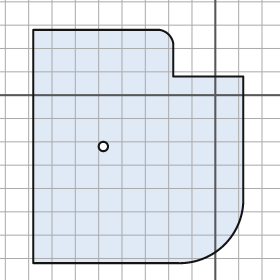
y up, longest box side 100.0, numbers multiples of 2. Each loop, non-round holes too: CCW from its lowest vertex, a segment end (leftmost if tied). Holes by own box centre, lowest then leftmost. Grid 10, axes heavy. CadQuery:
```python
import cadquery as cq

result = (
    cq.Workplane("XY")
    .moveTo(-78.0, -72.0)
    .lineTo(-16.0, -72.0)
    .threePointArc((4.0, -64.0), (12.0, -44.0))
    .lineTo(12.0, 8.0)
    .lineTo(-18.0, 8.0)
    .lineTo(-18.0, 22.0)
    .threePointArc((-20.0, 26.0), (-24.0, 28.0))
    .lineTo(-78.0, 28.0)
    .close()
    .moveTo(-48.0, -22.0)
    .circle(2.0)
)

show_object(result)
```